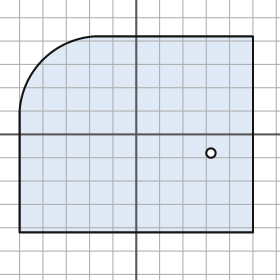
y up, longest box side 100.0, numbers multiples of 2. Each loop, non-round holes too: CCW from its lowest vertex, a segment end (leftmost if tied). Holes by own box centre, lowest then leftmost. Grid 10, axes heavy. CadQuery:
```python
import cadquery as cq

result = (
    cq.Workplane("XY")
    .moveTo(-50.0, -42.0)
    .lineTo(50.0, -42.0)
    .lineTo(50.0, 42.0)
    .lineTo(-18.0, 42.0)
    .threePointArc((-40.0, 32.0), (-50.0, 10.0))
    .close()
    .moveTo(32.0, -8.0)
    .circle(2.0)
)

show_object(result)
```